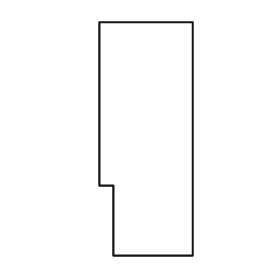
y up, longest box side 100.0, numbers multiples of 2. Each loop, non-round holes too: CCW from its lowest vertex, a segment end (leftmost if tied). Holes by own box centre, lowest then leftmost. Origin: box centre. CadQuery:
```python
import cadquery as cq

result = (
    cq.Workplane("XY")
    .moveTo(-14.0, -50.0)
    .lineTo(20.0, -50.0)
    .lineTo(20.0, 50.0)
    .lineTo(-20.0, 50.0)
    .lineTo(-20.0, -20.0)
    .lineTo(-14.0, -20.0)
    .close()
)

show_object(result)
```